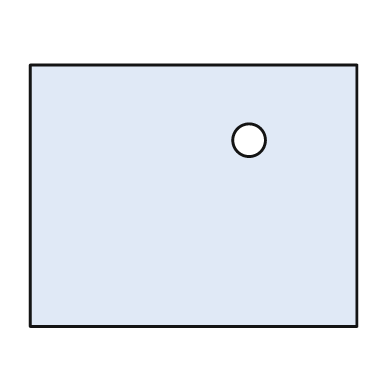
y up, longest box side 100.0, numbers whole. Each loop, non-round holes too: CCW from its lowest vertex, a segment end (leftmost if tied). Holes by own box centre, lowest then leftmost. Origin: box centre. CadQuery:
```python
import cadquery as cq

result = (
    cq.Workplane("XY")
    .moveTo(-50.0, -40.0)
    .lineTo(50.0, -40.0)
    .lineTo(50.0, 40.0)
    .lineTo(-50.0, 40.0)
    .close()
    .moveTo(17.0, 17.0)
    .circle(5.0)
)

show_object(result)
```